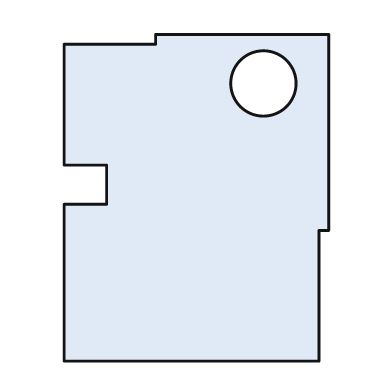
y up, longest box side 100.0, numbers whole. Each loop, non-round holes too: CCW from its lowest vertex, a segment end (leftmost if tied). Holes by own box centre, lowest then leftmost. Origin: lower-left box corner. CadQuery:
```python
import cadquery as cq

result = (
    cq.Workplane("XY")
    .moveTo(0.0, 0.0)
    .lineTo(78.0, 0.0)
    .lineTo(78.0, 40.0)
    .lineTo(81.0, 40.0)
    .lineTo(81.0, 100.0)
    .lineTo(28.0, 100.0)
    .lineTo(28.0, 97.0)
    .lineTo(0.0, 97.0)
    .lineTo(0.0, 60.0)
    .lineTo(13.0, 60.0)
    .lineTo(13.0, 48.0)
    .lineTo(0.0, 48.0)
    .close()
    .moveTo(61.0, 85.0)
    .circle(10.0)
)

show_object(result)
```